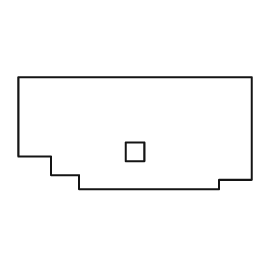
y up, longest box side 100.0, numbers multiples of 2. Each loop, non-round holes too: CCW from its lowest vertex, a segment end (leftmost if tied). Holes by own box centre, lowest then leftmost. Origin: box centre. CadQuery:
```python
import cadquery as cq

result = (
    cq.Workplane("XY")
    .moveTo(-24.0, -24.0)
    .lineTo(36.0, -24.0)
    .lineTo(36.0, -20.0)
    .lineTo(50.0, -20.0)
    .lineTo(50.0, 24.0)
    .lineTo(-50.0, 24.0)
    .lineTo(-50.0, -10.0)
    .lineTo(-36.0, -10.0)
    .lineTo(-36.0, -18.0)
    .lineTo(-24.0, -18.0)
    .close()
    .moveTo(-4.0, -12.0)
    .lineTo(4.0, -12.0)
    .lineTo(4.0, -4.0)
    .lineTo(-4.0, -4.0)
    .close()
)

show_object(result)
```